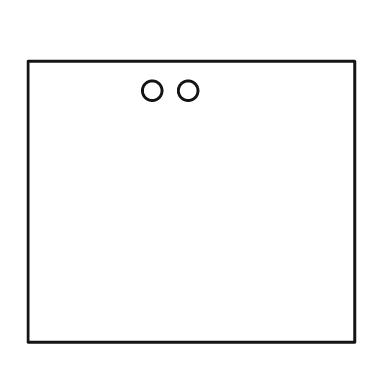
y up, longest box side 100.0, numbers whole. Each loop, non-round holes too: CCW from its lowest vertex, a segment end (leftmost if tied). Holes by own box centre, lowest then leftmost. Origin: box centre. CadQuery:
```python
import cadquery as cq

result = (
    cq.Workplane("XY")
    .moveTo(-50.0, -43.0)
    .lineTo(50.0, -43.0)
    .lineTo(50.0, 43.0)
    .lineTo(-50.0, 43.0)
    .close()
    .moveTo(-12.0, 34.0)
    .circle(3.0)
    .moveTo(-1.0, 34.0)
    .circle(3.0)
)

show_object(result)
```